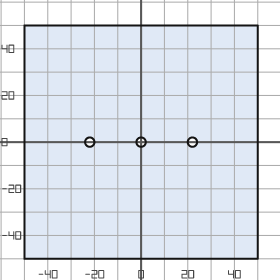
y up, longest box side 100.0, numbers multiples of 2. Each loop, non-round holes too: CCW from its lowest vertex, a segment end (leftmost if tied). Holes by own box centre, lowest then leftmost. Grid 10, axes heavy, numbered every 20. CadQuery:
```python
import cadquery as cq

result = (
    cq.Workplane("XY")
    .moveTo(-50.0, -50.0)
    .lineTo(50.0, -50.0)
    .lineTo(50.0, 50.0)
    .lineTo(-50.0, 50.0)
    .close()
    .moveTo(-22.0, 0.0)
    .circle(2.0)
    .moveTo(0.0, 0.0)
    .circle(2.0)
    .moveTo(22.0, 0.0)
    .circle(2.0)
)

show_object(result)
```